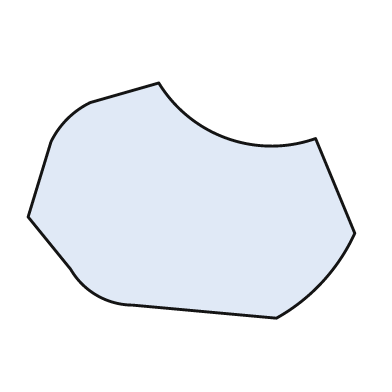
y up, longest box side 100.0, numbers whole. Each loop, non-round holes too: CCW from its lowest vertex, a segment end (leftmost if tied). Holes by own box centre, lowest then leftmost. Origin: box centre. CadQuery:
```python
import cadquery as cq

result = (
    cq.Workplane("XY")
    .moveTo(26.0, -36.0)
    .threePointArc((40.0, -25.0), (50.0, -10.0))
    .lineTo(38.0, 19.0)
    .threePointArc((11.0, 19.0), (-10.0, 36.0))
    .lineTo(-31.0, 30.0)
    .threePointArc((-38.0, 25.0), (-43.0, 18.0))
    .lineTo(-50.0, -5.0)
    .lineTo(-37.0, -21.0)
    .threePointArc((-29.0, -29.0), (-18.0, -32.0))
    .close()
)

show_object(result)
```